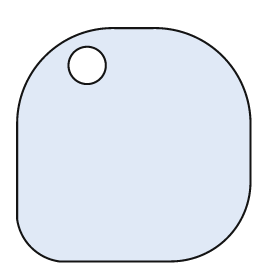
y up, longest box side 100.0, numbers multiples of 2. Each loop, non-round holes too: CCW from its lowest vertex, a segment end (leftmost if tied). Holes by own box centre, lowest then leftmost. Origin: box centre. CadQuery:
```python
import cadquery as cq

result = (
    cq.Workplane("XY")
    .moveTo(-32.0, -50.0)
    .lineTo(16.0, -50.0)
    .threePointArc((40.0, -40.0), (50.0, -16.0))
    .lineTo(50.0, 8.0)
    .threePointArc((38.0, 38.0), (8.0, 50.0))
    .lineTo(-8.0, 50.0)
    .threePointArc((-38.0, 38.0), (-50.0, 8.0))
    .lineTo(-50.0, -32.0)
    .threePointArc((-44.0, -44.0), (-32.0, -50.0))
    .close()
    .moveTo(-20.0, 34.0)
    .circle(8.0)
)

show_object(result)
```